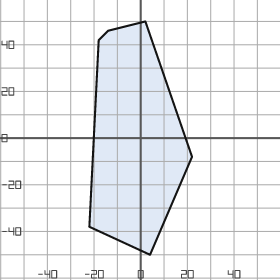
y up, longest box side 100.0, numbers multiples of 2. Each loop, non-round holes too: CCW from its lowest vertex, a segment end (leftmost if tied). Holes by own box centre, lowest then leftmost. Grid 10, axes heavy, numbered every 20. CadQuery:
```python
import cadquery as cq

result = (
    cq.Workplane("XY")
    .moveTo(4.0, -50.0)
    .lineTo(22.0, -8.0)
    .lineTo(2.0, 50.0)
    .lineTo(-14.0, 46.0)
    .lineTo(-18.0, 42.0)
    .lineTo(-22.0, -38.0)
    .close()
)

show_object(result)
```